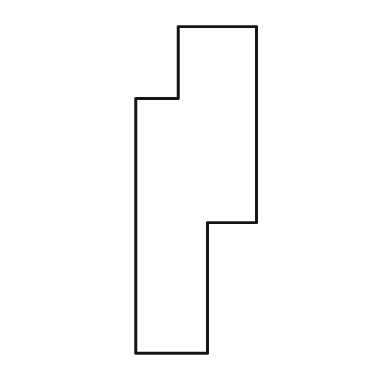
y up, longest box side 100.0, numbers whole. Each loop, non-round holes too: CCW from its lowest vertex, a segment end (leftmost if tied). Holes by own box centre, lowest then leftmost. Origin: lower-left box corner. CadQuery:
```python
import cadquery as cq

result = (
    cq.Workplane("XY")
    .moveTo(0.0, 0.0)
    .lineTo(22.0, 0.0)
    .lineTo(22.0, 40.0)
    .lineTo(37.0, 40.0)
    .lineTo(37.0, 100.0)
    .lineTo(13.0, 100.0)
    .lineTo(13.0, 78.0)
    .lineTo(0.0, 78.0)
    .close()
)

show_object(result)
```